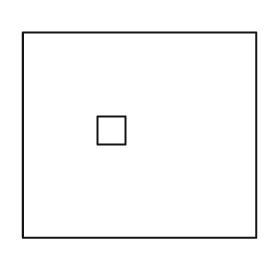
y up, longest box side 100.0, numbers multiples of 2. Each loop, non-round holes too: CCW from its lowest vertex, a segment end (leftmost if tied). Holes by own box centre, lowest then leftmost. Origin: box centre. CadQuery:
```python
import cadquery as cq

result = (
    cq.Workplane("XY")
    .moveTo(-50.0, -44.0)
    .lineTo(50.0, -44.0)
    .lineTo(50.0, 44.0)
    .lineTo(-50.0, 44.0)
    .close()
    .moveTo(-18.0, -4.0)
    .lineTo(-6.0, -4.0)
    .lineTo(-6.0, 8.0)
    .lineTo(-18.0, 8.0)
    .close()
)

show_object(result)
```